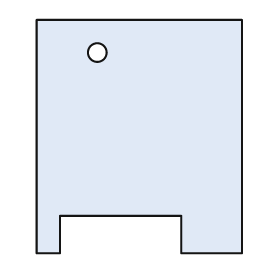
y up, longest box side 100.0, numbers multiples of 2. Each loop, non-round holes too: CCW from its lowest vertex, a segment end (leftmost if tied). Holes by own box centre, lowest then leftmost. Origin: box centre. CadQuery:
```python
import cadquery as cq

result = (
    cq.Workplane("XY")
    .moveTo(-44.0, -50.0)
    .lineTo(-34.0, -50.0)
    .lineTo(-34.0, -34.0)
    .lineTo(18.0, -34.0)
    .lineTo(18.0, -50.0)
    .lineTo(44.0, -50.0)
    .lineTo(44.0, 50.0)
    .lineTo(-44.0, 50.0)
    .close()
    .moveTo(-18.0, 36.0)
    .circle(4.0)
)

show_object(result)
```